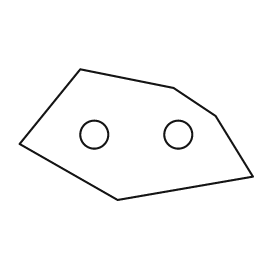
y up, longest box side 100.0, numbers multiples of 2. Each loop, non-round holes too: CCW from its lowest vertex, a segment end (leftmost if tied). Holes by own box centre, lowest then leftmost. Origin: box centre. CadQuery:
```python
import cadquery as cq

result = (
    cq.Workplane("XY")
    .moveTo(-8.0, -28.0)
    .lineTo(50.0, -18.0)
    .lineTo(34.0, 8.0)
    .lineTo(16.0, 20.0)
    .lineTo(-24.0, 28.0)
    .lineTo(-50.0, -4.0)
    .close()
    .moveTo(-18.0, 0.0)
    .circle(6.0)
    .moveTo(18.0, 0.0)
    .circle(6.0)
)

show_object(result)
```